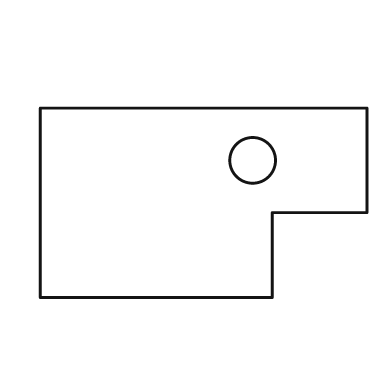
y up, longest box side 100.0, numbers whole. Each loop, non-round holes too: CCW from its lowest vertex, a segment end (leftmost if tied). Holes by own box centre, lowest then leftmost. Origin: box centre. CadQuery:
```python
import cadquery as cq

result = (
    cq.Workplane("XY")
    .moveTo(-50.0, -29.0)
    .lineTo(21.0, -29.0)
    .lineTo(21.0, -3.0)
    .lineTo(50.0, -3.0)
    .lineTo(50.0, 29.0)
    .lineTo(-50.0, 29.0)
    .close()
    .moveTo(15.0, 13.0)
    .circle(7.0)
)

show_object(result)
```